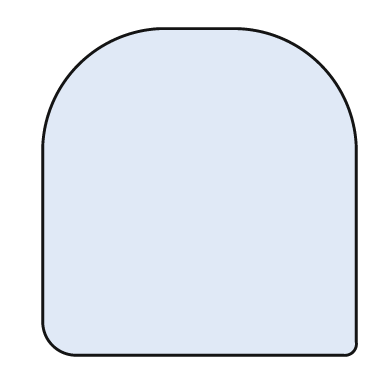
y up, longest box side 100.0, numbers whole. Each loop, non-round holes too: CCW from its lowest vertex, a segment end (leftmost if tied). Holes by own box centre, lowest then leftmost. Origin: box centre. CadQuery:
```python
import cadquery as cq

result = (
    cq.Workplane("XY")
    .moveTo(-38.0, -50.0)
    .lineTo(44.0, -50.0)
    .threePointArc((47.0, -49.0), (48.0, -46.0))
    .lineTo(48.0, 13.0)
    .threePointArc((37.0, 39.0), (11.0, 50.0))
    .lineTo(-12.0, 50.0)
    .threePointArc((-37.0, 39.0), (-48.0, 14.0))
    .lineTo(-48.0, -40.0)
    .threePointArc((-45.0, -47.0), (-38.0, -50.0))
    .close()
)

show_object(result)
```